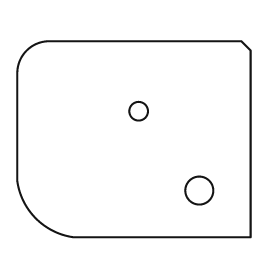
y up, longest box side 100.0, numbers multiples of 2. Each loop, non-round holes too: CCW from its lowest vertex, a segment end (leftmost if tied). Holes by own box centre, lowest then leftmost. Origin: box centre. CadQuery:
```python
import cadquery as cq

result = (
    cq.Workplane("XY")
    .moveTo(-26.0, -42.0)
    .lineTo(50.0, -42.0)
    .lineTo(50.0, 38.0)
    .lineTo(46.0, 42.0)
    .lineTo(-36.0, 42.0)
    .threePointArc((-46.0, 38.0), (-50.0, 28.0))
    .lineTo(-50.0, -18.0)
    .threePointArc((-42.0, -34.0), (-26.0, -42.0))
    .close()
    .moveTo(28.0, -22.0)
    .circle(6.0)
    .moveTo(2.0, 12.0)
    .circle(4.0)
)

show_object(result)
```